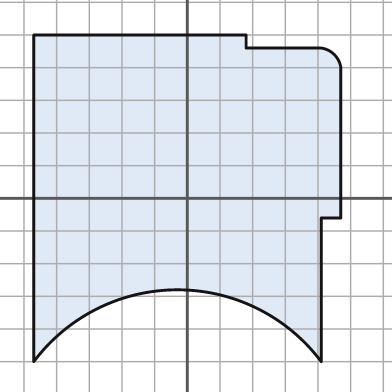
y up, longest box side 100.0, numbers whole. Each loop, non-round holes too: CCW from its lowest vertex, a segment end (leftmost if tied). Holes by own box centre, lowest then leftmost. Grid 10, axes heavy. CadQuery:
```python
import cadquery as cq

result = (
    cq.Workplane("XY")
    .moveTo(-47.0, -50.0)
    .threePointArc((-3.0, -28.0), (41.0, -50.0))
    .lineTo(41.0, -6.0)
    .lineTo(47.0, -6.0)
    .lineTo(47.0, 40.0)
    .threePointArc((45.0, 44.0), (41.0, 46.0))
    .lineTo(18.0, 46.0)
    .lineTo(18.0, 50.0)
    .lineTo(-47.0, 50.0)
    .close()
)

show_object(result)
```